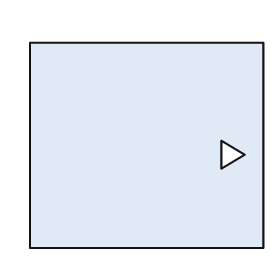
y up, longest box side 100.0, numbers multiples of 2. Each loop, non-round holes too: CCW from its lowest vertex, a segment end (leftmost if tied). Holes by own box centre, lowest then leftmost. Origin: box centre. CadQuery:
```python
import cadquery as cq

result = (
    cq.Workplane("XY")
    .moveTo(-50.0, -44.0)
    .lineTo(50.0, -44.0)
    .lineTo(50.0, 44.0)
    .lineTo(-50.0, 44.0)
    .close()
    .moveTo(32.0, -10.0)
    .lineTo(42.0, -4.0)
    .lineTo(32.0, 2.0)
    .close()
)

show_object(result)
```